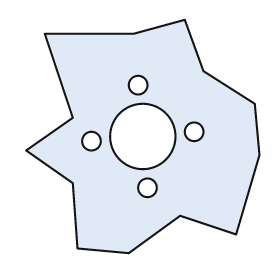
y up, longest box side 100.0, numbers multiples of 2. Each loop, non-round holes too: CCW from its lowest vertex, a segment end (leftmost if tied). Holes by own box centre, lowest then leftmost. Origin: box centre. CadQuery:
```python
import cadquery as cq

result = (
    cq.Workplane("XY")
    .moveTo(-6.0, -50.0)
    .lineTo(16.0, -34.0)
    .lineTo(40.0, -42.0)
    .lineTo(50.0, -8.0)
    .lineTo(48.0, 14.0)
    .lineTo(26.0, 28.0)
    .lineTo(18.0, 50.0)
    .lineTo(-4.0, 44.0)
    .lineTo(-42.0, 44.0)
    .lineTo(-30.0, 8.0)
    .lineTo(-50.0, -6.0)
    .lineTo(-30.0, -20.0)
    .lineTo(-28.0, -48.0)
    .close()
    .moveTo(2.0, -22.0)
    .circle(4.0)
    .moveTo(-22.0, -2.0)
    .circle(4.0)
    .moveTo(0.0, 0.0)
    .circle(14.0)
    .moveTo(22.0, 2.0)
    .circle(4.0)
    .moveTo(-2.0, 22.0)
    .circle(4.0)
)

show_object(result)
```